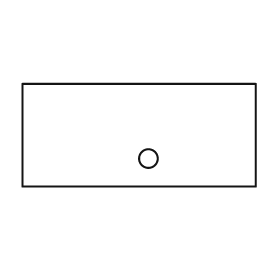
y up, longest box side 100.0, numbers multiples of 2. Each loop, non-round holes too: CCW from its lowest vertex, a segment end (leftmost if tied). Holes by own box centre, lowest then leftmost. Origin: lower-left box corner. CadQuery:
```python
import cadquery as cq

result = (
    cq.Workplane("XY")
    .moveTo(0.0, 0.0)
    .lineTo(100.0, 0.0)
    .lineTo(100.0, 44.0)
    .lineTo(0.0, 44.0)
    .close()
    .moveTo(54.0, 12.0)
    .circle(4.0)
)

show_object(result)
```